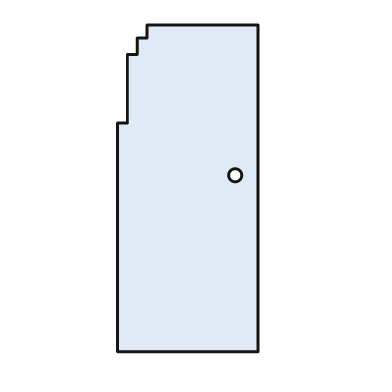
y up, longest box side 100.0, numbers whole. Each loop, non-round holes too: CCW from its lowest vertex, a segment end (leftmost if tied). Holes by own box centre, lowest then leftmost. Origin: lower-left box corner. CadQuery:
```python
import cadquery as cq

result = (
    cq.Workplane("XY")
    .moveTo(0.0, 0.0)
    .lineTo(43.0, 0.0)
    .lineTo(43.0, 100.0)
    .lineTo(9.0, 100.0)
    .lineTo(9.0, 96.0)
    .lineTo(6.0, 96.0)
    .lineTo(6.0, 91.0)
    .lineTo(3.0, 91.0)
    .lineTo(3.0, 70.0)
    .lineTo(0.0, 70.0)
    .close()
    .moveTo(36.0, 54.0)
    .circle(2.0)
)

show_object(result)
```